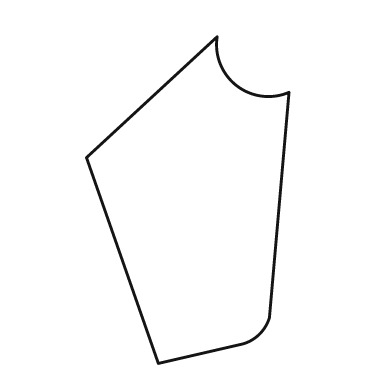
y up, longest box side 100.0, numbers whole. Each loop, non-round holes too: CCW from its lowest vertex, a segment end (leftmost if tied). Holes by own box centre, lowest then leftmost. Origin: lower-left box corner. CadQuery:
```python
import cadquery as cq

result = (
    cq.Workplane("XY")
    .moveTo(22.0, 0.0)
    .lineTo(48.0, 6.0)
    .threePointArc((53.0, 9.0), (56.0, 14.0))
    .lineTo(62.0, 83.0)
    .threePointArc((46.0, 85.0), (40.0, 100.0))
    .lineTo(0.0, 63.0)
    .close()
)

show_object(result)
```